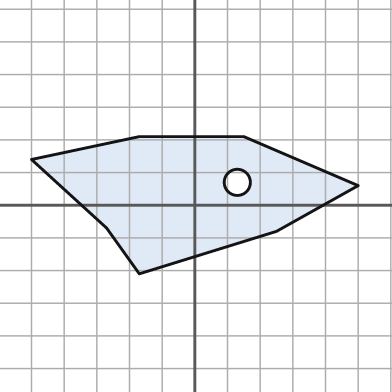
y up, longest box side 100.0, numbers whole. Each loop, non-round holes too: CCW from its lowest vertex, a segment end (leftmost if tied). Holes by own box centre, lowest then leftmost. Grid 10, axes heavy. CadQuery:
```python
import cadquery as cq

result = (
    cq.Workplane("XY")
    .moveTo(-17.0, -21.0)
    .lineTo(25.0, -8.0)
    .lineTo(50.0, 6.0)
    .lineTo(15.0, 21.0)
    .lineTo(-17.0, 21.0)
    .lineTo(-50.0, 14.0)
    .lineTo(-27.0, -7.0)
    .close()
    .moveTo(13.0, 7.0)
    .circle(4.0)
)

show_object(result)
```